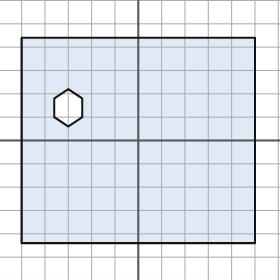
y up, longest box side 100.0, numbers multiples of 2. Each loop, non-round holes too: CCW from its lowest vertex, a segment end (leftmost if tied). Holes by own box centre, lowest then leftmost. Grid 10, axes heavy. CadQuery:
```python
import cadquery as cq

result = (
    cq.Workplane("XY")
    .moveTo(-50.0, -44.0)
    .lineTo(50.0, -44.0)
    .lineTo(50.0, 44.0)
    .lineTo(-50.0, 44.0)
    .close()
    .moveTo(-30.0, 6.0)
    .lineTo(-24.0, 10.0)
    .lineTo(-24.0, 18.0)
    .lineTo(-30.0, 22.0)
    .lineTo(-36.0, 18.0)
    .lineTo(-36.0, 10.0)
    .close()
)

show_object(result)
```